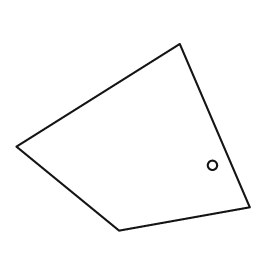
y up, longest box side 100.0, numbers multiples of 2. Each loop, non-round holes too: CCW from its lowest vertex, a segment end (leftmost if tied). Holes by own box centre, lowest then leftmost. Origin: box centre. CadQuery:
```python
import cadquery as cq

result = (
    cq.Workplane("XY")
    .moveTo(-6.0, -40.0)
    .lineTo(50.0, -30.0)
    .lineTo(20.0, 40.0)
    .lineTo(-50.0, -4.0)
    .close()
    .moveTo(34.0, -12.0)
    .circle(2.0)
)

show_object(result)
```